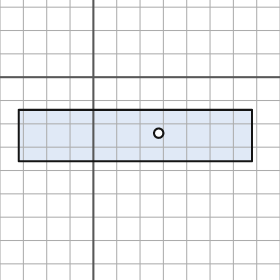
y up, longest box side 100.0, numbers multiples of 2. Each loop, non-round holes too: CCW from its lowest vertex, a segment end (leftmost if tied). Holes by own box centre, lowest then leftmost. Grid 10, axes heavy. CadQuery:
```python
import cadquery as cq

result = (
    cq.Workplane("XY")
    .moveTo(-32.0, -36.0)
    .lineTo(68.0, -36.0)
    .lineTo(68.0, -14.0)
    .lineTo(-32.0, -14.0)
    .close()
    .moveTo(28.0, -24.0)
    .circle(2.0)
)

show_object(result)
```